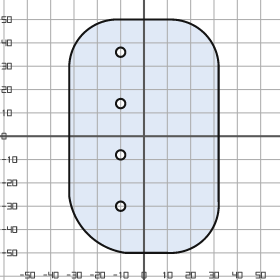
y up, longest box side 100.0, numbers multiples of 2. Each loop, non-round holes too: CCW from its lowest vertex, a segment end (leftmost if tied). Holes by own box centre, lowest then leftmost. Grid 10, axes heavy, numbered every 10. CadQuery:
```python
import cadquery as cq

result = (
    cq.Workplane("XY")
    .moveTo(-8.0, -50.0)
    .lineTo(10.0, -50.0)
    .threePointArc((26.0, -44.0), (32.0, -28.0))
    .lineTo(32.0, 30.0)
    .threePointArc((26.0, 44.0), (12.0, 50.0))
    .lineTo(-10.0, 50.0)
    .threePointArc((-26.0, 44.0), (-32.0, 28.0))
    .lineTo(-32.0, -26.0)
    .threePointArc((-24.0, -42.0), (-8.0, -50.0))
    .close()
    .moveTo(-10.0, -30.0)
    .circle(2.0)
    .moveTo(-10.0, -8.0)
    .circle(2.0)
    .moveTo(-10.0, 14.0)
    .circle(2.0)
    .moveTo(-10.0, 36.0)
    .circle(2.0)
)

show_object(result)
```